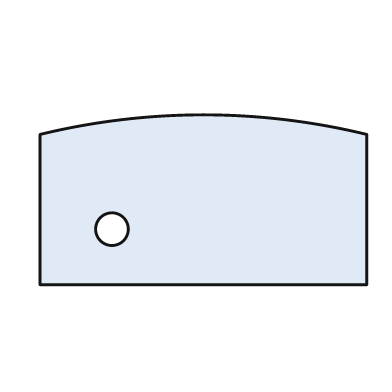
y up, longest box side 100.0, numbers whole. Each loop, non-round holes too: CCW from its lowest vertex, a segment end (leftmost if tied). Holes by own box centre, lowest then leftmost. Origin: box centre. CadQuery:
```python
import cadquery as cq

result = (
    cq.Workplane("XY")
    .moveTo(-50.0, -26.0)
    .lineTo(50.0, -26.0)
    .lineTo(50.0, 20.0)
    .threePointArc((0.0, 26.0), (-50.0, 20.0))
    .close()
    .moveTo(-28.0, -9.0)
    .circle(5.0)
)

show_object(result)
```